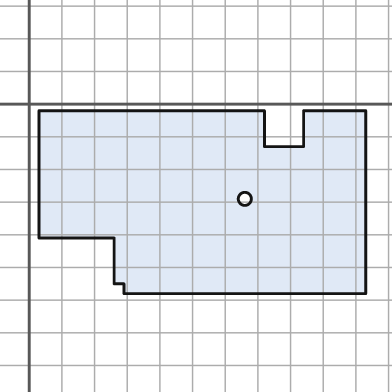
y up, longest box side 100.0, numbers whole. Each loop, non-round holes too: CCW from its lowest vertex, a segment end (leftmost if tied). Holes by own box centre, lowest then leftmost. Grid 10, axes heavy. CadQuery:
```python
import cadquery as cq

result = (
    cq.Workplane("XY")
    .moveTo(29.0, -58.0)
    .lineTo(103.0, -58.0)
    .lineTo(103.0, -2.0)
    .lineTo(84.0, -2.0)
    .lineTo(84.0, -13.0)
    .lineTo(72.0, -13.0)
    .lineTo(72.0, -2.0)
    .lineTo(3.0, -2.0)
    .lineTo(3.0, -41.0)
    .lineTo(26.0, -41.0)
    .lineTo(26.0, -55.0)
    .lineTo(29.0, -55.0)
    .close()
    .moveTo(66.0, -29.0)
    .circle(2.0)
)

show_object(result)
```